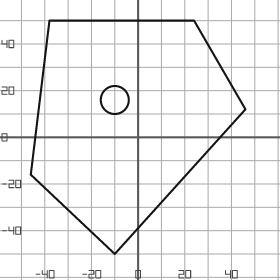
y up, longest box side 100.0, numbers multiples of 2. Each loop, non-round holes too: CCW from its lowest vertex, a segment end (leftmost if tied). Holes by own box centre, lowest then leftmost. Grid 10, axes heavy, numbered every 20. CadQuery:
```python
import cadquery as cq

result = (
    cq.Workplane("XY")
    .moveTo(-10.0, -50.0)
    .lineTo(46.0, 12.0)
    .lineTo(24.0, 50.0)
    .lineTo(-38.0, 50.0)
    .lineTo(-46.0, -16.0)
    .close()
    .moveTo(-10.0, 16.0)
    .circle(6.0)
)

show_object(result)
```